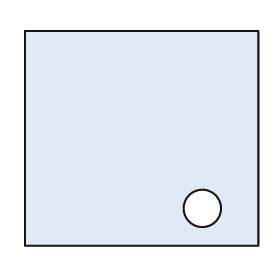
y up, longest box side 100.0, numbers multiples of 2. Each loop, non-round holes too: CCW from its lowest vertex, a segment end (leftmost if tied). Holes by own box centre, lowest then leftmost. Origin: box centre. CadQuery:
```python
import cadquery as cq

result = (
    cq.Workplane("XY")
    .moveTo(-50.0, -46.0)
    .lineTo(50.0, -46.0)
    .lineTo(50.0, 46.0)
    .lineTo(-50.0, 46.0)
    .close()
    .moveTo(26.0, -30.0)
    .circle(8.0)
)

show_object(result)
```